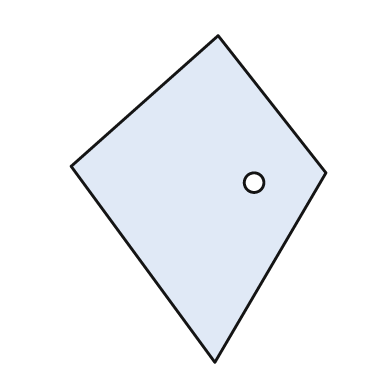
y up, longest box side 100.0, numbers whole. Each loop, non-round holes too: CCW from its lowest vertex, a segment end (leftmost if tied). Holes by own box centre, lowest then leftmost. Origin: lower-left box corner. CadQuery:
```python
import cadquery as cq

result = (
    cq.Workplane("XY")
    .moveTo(44.0, 0.0)
    .lineTo(78.0, 58.0)
    .lineTo(45.0, 100.0)
    .lineTo(0.0, 60.0)
    .close()
    .moveTo(56.0, 55.0)
    .circle(3.0)
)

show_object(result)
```